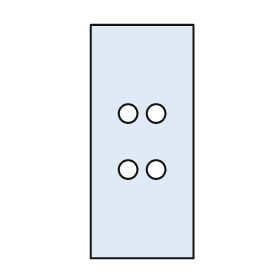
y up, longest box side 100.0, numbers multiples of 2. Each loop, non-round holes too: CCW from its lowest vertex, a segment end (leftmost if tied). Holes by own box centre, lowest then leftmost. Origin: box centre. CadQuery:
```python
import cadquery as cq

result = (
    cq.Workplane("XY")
    .moveTo(-22.0, -50.0)
    .lineTo(22.0, -50.0)
    .lineTo(22.0, 50.0)
    .lineTo(-22.0, 50.0)
    .close()
    .moveTo(-6.0, -12.0)
    .circle(4.0)
    .moveTo(6.0, -12.0)
    .circle(4.0)
    .moveTo(-6.0, 12.0)
    .circle(4.0)
    .moveTo(6.0, 12.0)
    .circle(4.0)
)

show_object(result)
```